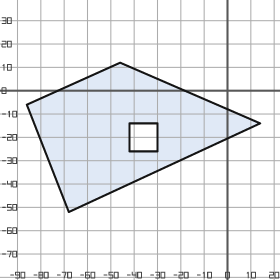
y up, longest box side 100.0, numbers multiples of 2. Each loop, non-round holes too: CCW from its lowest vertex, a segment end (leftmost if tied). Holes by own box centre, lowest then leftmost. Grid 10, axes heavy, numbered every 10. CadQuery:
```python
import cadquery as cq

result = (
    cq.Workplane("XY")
    .moveTo(-68.0, -52.0)
    .lineTo(14.0, -14.0)
    .lineTo(-46.0, 12.0)
    .lineTo(-86.0, -6.0)
    .close()
    .moveTo(-42.0, -26.0)
    .lineTo(-30.0, -26.0)
    .lineTo(-30.0, -14.0)
    .lineTo(-42.0, -14.0)
    .close()
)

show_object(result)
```